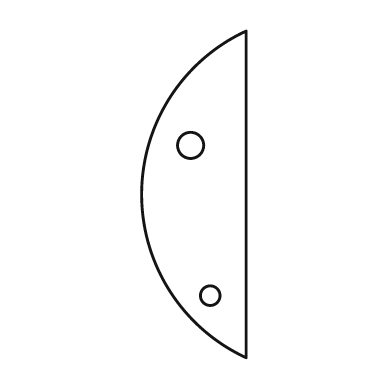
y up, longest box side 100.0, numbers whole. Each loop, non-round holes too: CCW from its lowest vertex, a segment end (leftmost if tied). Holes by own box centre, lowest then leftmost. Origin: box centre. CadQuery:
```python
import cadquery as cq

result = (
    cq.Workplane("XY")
    .moveTo(16.0, -50.0)
    .lineTo(16.0, 50.0)
    .threePointArc((-16.0, 0.0), (16.0, -50.0))
    .close()
    .moveTo(5.0, -31.0)
    .circle(3.0)
    .moveTo(-1.0, 15.0)
    .circle(4.0)
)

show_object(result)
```